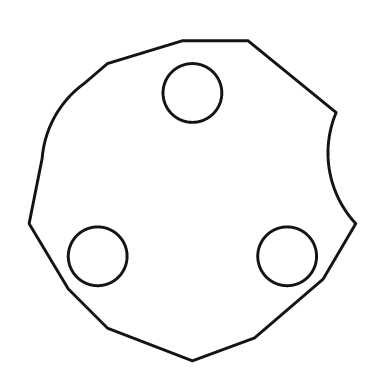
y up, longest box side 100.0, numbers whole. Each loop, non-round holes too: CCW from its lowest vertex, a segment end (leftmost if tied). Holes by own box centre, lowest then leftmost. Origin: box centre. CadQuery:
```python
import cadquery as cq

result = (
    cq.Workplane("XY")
    .moveTo(0.0, -49.0)
    .lineTo(19.0, -42.0)
    .lineTo(40.0, -24.0)
    .lineTo(50.0, -7.0)
    .threePointArc((42.0, 9.0), (44.0, 27.0))
    .lineTo(17.0, 49.0)
    .lineTo(-3.0, 49.0)
    .lineTo(-26.0, 42.0)
    .lineTo(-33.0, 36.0)
    .threePointArc((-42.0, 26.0), (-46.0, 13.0))
    .lineTo(-50.0, -7.0)
    .lineTo(-38.0, -27.0)
    .lineTo(-26.0, -39.0)
    .close()
    .moveTo(-29.0, -17.0)
    .circle(9.0)
    .moveTo(29.0, -17.0)
    .circle(9.0)
    .moveTo(0.0, 33.0)
    .circle(9.0)
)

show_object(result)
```